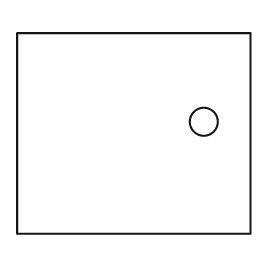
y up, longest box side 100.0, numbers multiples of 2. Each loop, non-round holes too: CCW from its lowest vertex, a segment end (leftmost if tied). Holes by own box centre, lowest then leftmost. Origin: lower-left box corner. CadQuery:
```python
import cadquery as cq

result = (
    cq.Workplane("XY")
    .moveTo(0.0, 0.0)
    .lineTo(100.0, 0.0)
    .lineTo(100.0, 86.0)
    .lineTo(0.0, 86.0)
    .close()
    .moveTo(80.0, 48.0)
    .circle(6.0)
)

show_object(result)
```